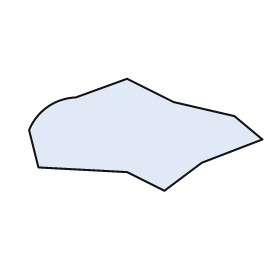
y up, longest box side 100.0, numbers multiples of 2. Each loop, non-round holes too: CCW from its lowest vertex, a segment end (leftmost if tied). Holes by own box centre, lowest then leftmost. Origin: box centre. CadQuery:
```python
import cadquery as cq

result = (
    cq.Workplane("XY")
    .moveTo(8.0, -24.0)
    .lineTo(24.0, -12.0)
    .lineTo(50.0, -2.0)
    .lineTo(38.0, 8.0)
    .lineTo(12.0, 14.0)
    .lineTo(-8.0, 24.0)
    .lineTo(-30.0, 16.0)
    .threePointArc((-42.0, 12.0), (-50.0, 2.0))
    .lineTo(-46.0, -14.0)
    .lineTo(-8.0, -16.0)
    .close()
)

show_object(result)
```